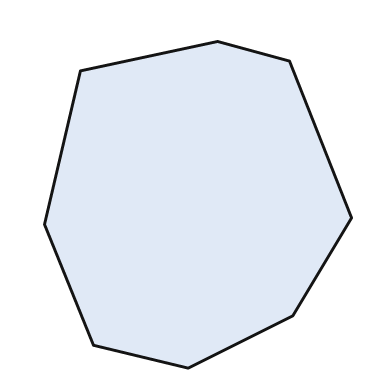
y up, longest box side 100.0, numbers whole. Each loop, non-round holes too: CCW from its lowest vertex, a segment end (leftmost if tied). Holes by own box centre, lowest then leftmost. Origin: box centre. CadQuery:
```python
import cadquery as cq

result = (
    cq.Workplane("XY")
    .moveTo(-3.0, -50.0)
    .lineTo(29.0, -34.0)
    .lineTo(47.0, -4.0)
    .lineTo(28.0, 44.0)
    .lineTo(6.0, 50.0)
    .lineTo(-36.0, 41.0)
    .lineTo(-47.0, -6.0)
    .lineTo(-32.0, -43.0)
    .close()
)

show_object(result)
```